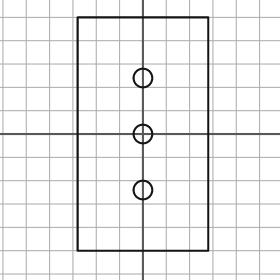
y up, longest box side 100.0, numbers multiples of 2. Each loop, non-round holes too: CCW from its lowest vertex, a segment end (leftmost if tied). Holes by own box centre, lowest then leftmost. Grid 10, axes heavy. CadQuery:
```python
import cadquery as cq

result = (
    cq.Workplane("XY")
    .moveTo(-28.0, -50.0)
    .lineTo(28.0, -50.0)
    .lineTo(28.0, 50.0)
    .lineTo(-28.0, 50.0)
    .close()
    .moveTo(0.0, -24.0)
    .circle(4.0)
    .moveTo(0.0, 0.0)
    .circle(4.0)
    .moveTo(0.0, 24.0)
    .circle(4.0)
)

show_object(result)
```